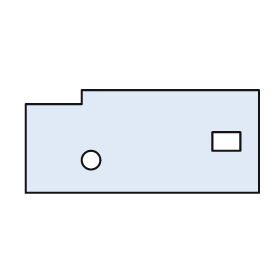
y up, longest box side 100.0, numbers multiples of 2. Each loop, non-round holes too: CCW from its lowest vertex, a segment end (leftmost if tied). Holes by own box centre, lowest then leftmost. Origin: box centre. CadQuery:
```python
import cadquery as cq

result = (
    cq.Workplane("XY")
    .moveTo(-50.0, -22.0)
    .lineTo(50.0, -22.0)
    .lineTo(50.0, 22.0)
    .lineTo(-26.0, 22.0)
    .lineTo(-26.0, 16.0)
    .lineTo(-50.0, 16.0)
    .close()
    .moveTo(-22.0, -8.0)
    .circle(4.0)
    .moveTo(30.0, -4.0)
    .lineTo(42.0, -4.0)
    .lineTo(42.0, 4.0)
    .lineTo(30.0, 4.0)
    .close()
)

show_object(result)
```